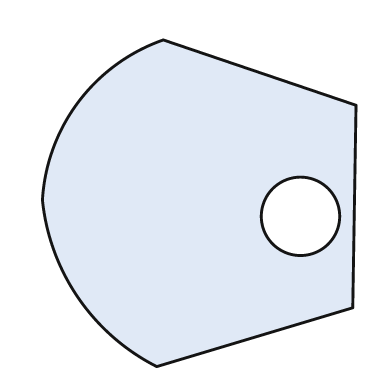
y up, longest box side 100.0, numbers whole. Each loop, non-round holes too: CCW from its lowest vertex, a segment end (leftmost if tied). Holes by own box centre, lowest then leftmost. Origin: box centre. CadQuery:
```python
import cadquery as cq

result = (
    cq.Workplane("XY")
    .moveTo(-13.0, -50.0)
    .lineTo(47.0, -32.0)
    .lineTo(48.0, 30.0)
    .lineTo(-11.0, 50.0)
    .threePointArc((-37.0, 31.0), (-48.0, 1.0))
    .threePointArc((-37.0, -29.0), (-13.0, -50.0))
    .close()
    .moveTo(31.0, -4.0)
    .circle(12.0)
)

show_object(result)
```